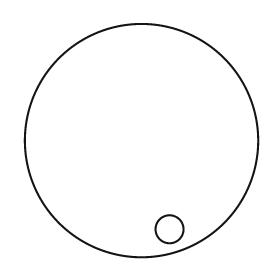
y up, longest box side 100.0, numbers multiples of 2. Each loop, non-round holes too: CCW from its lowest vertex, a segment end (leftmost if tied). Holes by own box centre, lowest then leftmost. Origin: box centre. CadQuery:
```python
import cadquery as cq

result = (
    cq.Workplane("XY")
    .moveTo(0.0, 0.0)
    .circle(50.0)
    .moveTo(12.0, -38.0)
    .circle(6.0)
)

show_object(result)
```